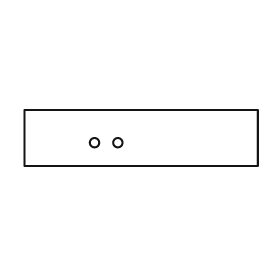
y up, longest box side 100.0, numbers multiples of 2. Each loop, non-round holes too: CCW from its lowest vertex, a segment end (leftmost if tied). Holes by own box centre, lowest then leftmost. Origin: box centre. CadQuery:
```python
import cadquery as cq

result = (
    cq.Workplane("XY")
    .moveTo(-50.0, -12.0)
    .lineTo(50.0, -12.0)
    .lineTo(50.0, 12.0)
    .lineTo(-50.0, 12.0)
    .close()
    .moveTo(-20.0, -2.0)
    .circle(2.0)
    .moveTo(-10.0, -2.0)
    .circle(2.0)
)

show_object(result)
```